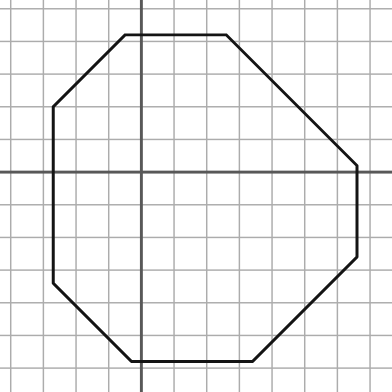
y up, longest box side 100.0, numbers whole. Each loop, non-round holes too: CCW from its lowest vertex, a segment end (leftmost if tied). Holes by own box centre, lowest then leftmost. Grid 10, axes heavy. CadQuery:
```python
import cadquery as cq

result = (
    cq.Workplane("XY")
    .moveTo(-3.0, -58.0)
    .lineTo(34.0, -58.0)
    .lineTo(66.0, -26.0)
    .lineTo(66.0, 2.0)
    .lineTo(26.0, 42.0)
    .lineTo(-5.0, 42.0)
    .lineTo(-27.0, 20.0)
    .lineTo(-27.0, -34.0)
    .close()
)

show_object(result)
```